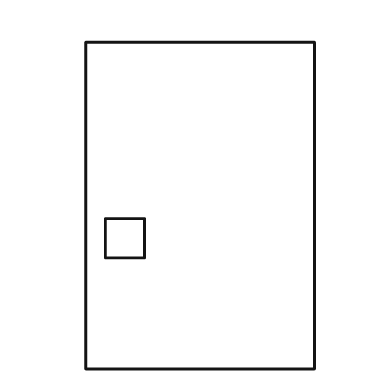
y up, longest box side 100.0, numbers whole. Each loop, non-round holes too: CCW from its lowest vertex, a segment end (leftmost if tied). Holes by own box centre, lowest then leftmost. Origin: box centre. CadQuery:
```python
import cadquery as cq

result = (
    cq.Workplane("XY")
    .moveTo(-35.0, -50.0)
    .lineTo(35.0, -50.0)
    .lineTo(35.0, 50.0)
    .lineTo(-35.0, 50.0)
    .close()
    .moveTo(-29.0, -16.0)
    .lineTo(-17.0, -16.0)
    .lineTo(-17.0, -4.0)
    .lineTo(-29.0, -4.0)
    .close()
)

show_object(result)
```